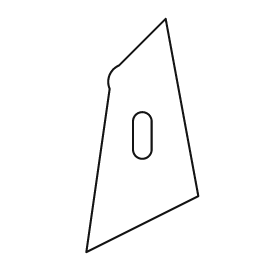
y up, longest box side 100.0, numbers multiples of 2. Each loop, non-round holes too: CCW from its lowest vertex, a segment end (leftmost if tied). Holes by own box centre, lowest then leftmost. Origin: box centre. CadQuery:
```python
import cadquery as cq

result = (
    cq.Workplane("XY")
    .moveTo(-24.0, -50.0)
    .lineTo(24.0, -26.0)
    .lineTo(10.0, 50.0)
    .lineTo(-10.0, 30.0)
    .threePointArc((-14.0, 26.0), (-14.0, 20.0))
    .close()
    .moveTo(-4.0, -6.0)
    .threePointArc((0.0, -10.0), (4.0, -6.0))
    .lineTo(4.0, 6.0)
    .threePointArc((0.0, 10.0), (-4.0, 6.0))
    .close()
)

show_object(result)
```